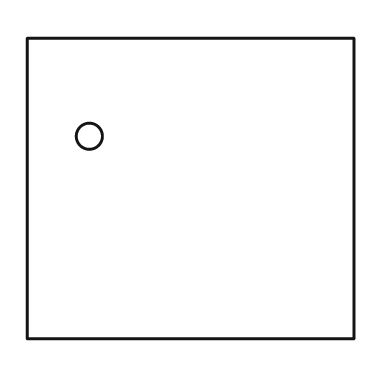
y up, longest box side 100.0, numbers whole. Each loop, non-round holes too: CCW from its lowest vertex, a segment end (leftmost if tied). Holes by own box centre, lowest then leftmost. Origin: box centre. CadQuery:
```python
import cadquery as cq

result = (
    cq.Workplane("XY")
    .moveTo(-50.0, -46.0)
    .lineTo(50.0, -46.0)
    .lineTo(50.0, 46.0)
    .lineTo(-50.0, 46.0)
    .close()
    .moveTo(-31.0, 16.0)
    .circle(4.0)
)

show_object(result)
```